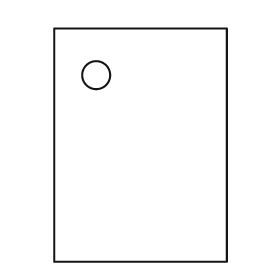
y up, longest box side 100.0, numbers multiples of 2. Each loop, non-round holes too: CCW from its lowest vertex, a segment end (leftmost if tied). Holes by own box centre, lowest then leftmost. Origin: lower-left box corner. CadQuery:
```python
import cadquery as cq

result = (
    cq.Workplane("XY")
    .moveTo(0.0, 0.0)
    .lineTo(74.0, 0.0)
    .lineTo(74.0, 100.0)
    .lineTo(0.0, 100.0)
    .close()
    .moveTo(18.0, 80.0)
    .circle(6.0)
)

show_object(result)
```